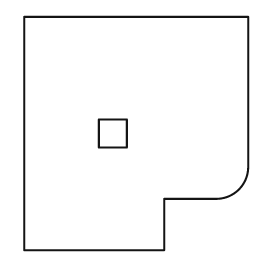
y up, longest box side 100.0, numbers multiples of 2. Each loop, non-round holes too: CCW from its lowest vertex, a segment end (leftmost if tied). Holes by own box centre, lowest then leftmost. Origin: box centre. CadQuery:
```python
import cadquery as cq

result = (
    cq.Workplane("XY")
    .moveTo(-48.0, -50.0)
    .lineTo(12.0, -50.0)
    .lineTo(12.0, -28.0)
    .lineTo(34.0, -28.0)
    .threePointArc((44.0, -24.0), (48.0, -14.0))
    .lineTo(48.0, 50.0)
    .lineTo(-48.0, 50.0)
    .close()
    .moveTo(-16.0, -6.0)
    .lineTo(-4.0, -6.0)
    .lineTo(-4.0, 6.0)
    .lineTo(-16.0, 6.0)
    .close()
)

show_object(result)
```